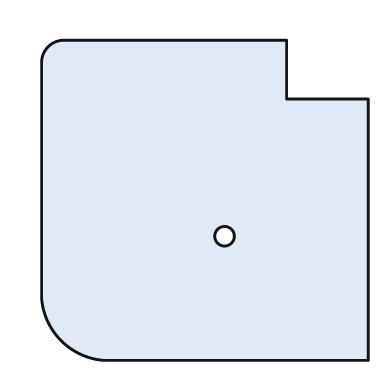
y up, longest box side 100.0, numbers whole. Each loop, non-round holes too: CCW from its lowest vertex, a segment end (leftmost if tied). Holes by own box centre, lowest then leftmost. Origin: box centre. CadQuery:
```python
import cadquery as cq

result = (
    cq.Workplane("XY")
    .moveTo(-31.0, -49.0)
    .lineTo(50.0, -49.0)
    .lineTo(50.0, 31.0)
    .lineTo(25.0, 31.0)
    .lineTo(25.0, 49.0)
    .lineTo(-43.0, 49.0)
    .threePointArc((-48.0, 47.0), (-50.0, 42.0))
    .lineTo(-50.0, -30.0)
    .threePointArc((-44.0, -43.0), (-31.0, -49.0))
    .close()
    .moveTo(6.0, -11.0)
    .circle(3.0)
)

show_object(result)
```